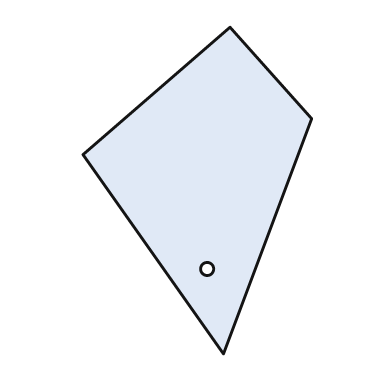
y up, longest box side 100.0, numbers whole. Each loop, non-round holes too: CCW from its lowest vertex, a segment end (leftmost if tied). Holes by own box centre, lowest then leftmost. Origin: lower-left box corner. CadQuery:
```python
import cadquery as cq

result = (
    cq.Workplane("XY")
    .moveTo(43.0, 0.0)
    .lineTo(70.0, 72.0)
    .lineTo(45.0, 100.0)
    .lineTo(0.0, 61.0)
    .close()
    .moveTo(38.0, 26.0)
    .circle(2.0)
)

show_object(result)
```